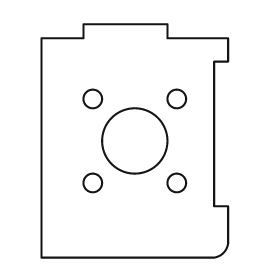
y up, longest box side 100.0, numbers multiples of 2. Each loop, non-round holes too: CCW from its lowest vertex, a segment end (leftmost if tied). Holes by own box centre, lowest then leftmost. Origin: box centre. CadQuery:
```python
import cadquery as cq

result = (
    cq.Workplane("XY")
    .moveTo(-40.0, -50.0)
    .lineTo(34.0, -50.0)
    .threePointArc((38.0, -48.0), (40.0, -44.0))
    .lineTo(40.0, -28.0)
    .lineTo(34.0, -28.0)
    .lineTo(34.0, 34.0)
    .lineTo(40.0, 34.0)
    .lineTo(40.0, 44.0)
    .lineTo(14.0, 44.0)
    .lineTo(14.0, 50.0)
    .lineTo(-22.0, 50.0)
    .lineTo(-22.0, 44.0)
    .lineTo(-40.0, 44.0)
    .close()
    .moveTo(-18.0, -18.0)
    .circle(4.0)
    .moveTo(18.0, -18.0)
    .circle(4.0)
    .moveTo(0.0, 0.0)
    .circle(14.0)
    .moveTo(-18.0, 18.0)
    .circle(4.0)
    .moveTo(18.0, 18.0)
    .circle(4.0)
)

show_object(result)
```